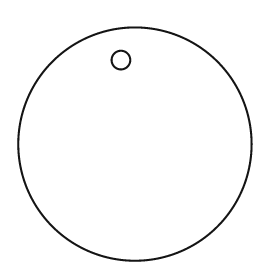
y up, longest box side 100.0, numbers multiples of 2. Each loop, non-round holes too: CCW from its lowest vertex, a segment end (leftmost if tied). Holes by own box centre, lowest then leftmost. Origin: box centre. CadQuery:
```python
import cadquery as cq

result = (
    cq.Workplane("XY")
    .moveTo(0.0, 0.0)
    .circle(50.0)
    .moveTo(-6.0, 36.0)
    .circle(4.0)
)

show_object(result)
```